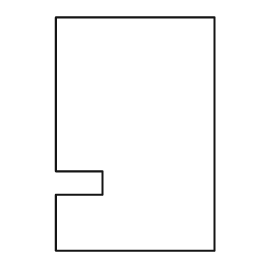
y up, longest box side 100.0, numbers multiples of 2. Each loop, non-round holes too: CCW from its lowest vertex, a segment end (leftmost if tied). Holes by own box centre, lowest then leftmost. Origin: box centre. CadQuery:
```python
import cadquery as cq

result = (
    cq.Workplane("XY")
    .moveTo(-34.0, -50.0)
    .lineTo(34.0, -50.0)
    .lineTo(34.0, 50.0)
    .lineTo(-34.0, 50.0)
    .lineTo(-34.0, -16.0)
    .lineTo(-14.0, -16.0)
    .lineTo(-14.0, -26.0)
    .lineTo(-34.0, -26.0)
    .close()
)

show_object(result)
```